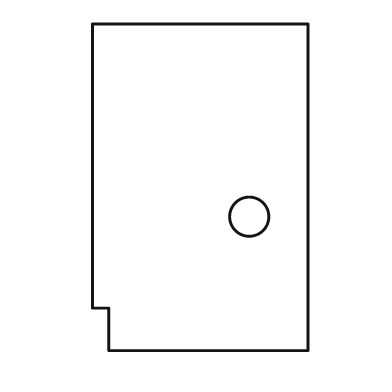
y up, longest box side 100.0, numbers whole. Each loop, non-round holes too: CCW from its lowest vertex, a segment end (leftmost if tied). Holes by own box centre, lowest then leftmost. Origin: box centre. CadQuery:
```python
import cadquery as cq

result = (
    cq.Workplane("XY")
    .moveTo(-28.0, -50.0)
    .lineTo(33.0, -50.0)
    .lineTo(33.0, 50.0)
    .lineTo(-33.0, 50.0)
    .lineTo(-33.0, -37.0)
    .lineTo(-28.0, -37.0)
    .close()
    .moveTo(15.0, -9.0)
    .circle(6.0)
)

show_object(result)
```